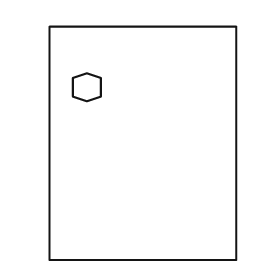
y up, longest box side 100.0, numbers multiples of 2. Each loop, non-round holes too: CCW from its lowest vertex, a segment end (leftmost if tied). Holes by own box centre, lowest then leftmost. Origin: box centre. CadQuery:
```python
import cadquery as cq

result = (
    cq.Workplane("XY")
    .moveTo(-40.0, -50.0)
    .lineTo(40.0, -50.0)
    .lineTo(40.0, 50.0)
    .lineTo(-40.0, 50.0)
    .close()
    .moveTo(-24.0, 18.0)
    .lineTo(-18.0, 20.0)
    .lineTo(-18.0, 28.0)
    .lineTo(-24.0, 30.0)
    .lineTo(-30.0, 28.0)
    .lineTo(-30.0, 20.0)
    .close()
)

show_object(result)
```